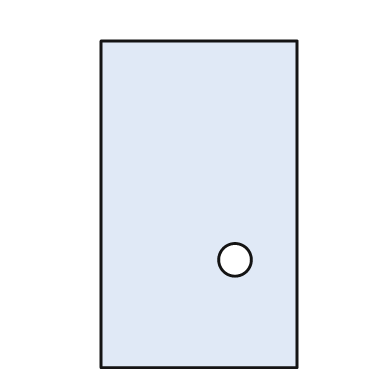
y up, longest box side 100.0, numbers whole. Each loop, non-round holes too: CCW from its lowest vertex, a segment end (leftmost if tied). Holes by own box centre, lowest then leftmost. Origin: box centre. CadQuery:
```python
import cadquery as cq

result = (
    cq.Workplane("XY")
    .moveTo(-30.0, -50.0)
    .lineTo(30.0, -50.0)
    .lineTo(30.0, 50.0)
    .lineTo(-30.0, 50.0)
    .close()
    .moveTo(11.0, -17.0)
    .circle(5.0)
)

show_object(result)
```